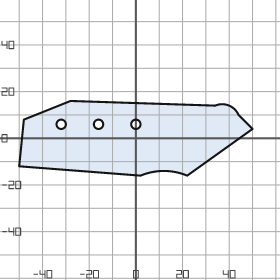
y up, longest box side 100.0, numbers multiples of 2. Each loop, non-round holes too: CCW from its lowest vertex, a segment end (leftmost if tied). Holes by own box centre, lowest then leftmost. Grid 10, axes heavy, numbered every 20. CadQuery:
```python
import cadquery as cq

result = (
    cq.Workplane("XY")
    .moveTo(2.0, -16.0)
    .threePointArc((12.0, -14.0), (22.0, -16.0))
    .lineTo(50.0, 4.0)
    .lineTo(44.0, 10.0)
    .threePointArc((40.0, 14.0), (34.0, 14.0))
    .lineTo(-28.0, 16.0)
    .lineTo(-48.0, 8.0)
    .lineTo(-50.0, -12.0)
    .close()
    .moveTo(-32.0, 6.0)
    .circle(2.0)
    .moveTo(-16.0, 6.0)
    .circle(2.0)
    .moveTo(0.0, 6.0)
    .circle(2.0)
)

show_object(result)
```